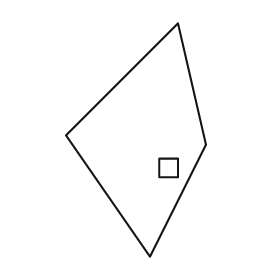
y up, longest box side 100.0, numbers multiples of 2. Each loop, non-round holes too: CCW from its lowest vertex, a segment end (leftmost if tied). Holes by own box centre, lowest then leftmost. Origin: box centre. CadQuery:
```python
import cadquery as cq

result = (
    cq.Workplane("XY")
    .moveTo(6.0, -50.0)
    .lineTo(30.0, -2.0)
    .lineTo(18.0, 50.0)
    .lineTo(-30.0, 2.0)
    .close()
    .moveTo(10.0, -16.0)
    .lineTo(18.0, -16.0)
    .lineTo(18.0, -8.0)
    .lineTo(10.0, -8.0)
    .close()
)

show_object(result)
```